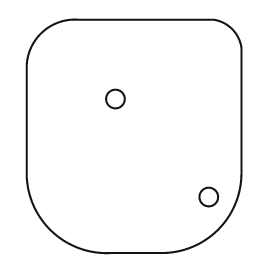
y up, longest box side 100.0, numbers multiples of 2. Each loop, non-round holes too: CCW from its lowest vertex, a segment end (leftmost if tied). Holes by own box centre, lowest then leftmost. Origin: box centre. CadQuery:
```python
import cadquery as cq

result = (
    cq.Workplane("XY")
    .moveTo(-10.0, -50.0)
    .lineTo(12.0, -50.0)
    .threePointArc((36.0, -40.0), (46.0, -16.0))
    .lineTo(46.0, 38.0)
    .threePointArc((42.0, 46.0), (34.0, 50.0))
    .lineTo(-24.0, 50.0)
    .threePointArc((-40.0, 44.0), (-46.0, 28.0))
    .lineTo(-46.0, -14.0)
    .threePointArc((-36.0, -40.0), (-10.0, -50.0))
    .close()
    .moveTo(32.0, -26.0)
    .circle(4.0)
    .moveTo(-8.0, 16.0)
    .circle(4.0)
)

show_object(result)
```